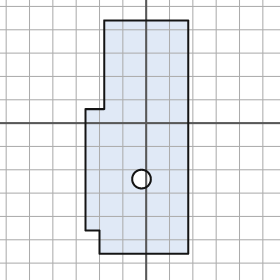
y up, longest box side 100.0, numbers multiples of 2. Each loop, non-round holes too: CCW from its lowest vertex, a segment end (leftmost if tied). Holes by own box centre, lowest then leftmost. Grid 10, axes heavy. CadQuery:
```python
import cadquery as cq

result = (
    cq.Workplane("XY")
    .moveTo(-20.0, -56.0)
    .lineTo(18.0, -56.0)
    .lineTo(18.0, 44.0)
    .lineTo(-18.0, 44.0)
    .lineTo(-18.0, 6.0)
    .lineTo(-26.0, 6.0)
    .lineTo(-26.0, -46.0)
    .lineTo(-20.0, -46.0)
    .close()
    .moveTo(-2.0, -24.0)
    .circle(4.0)
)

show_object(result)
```